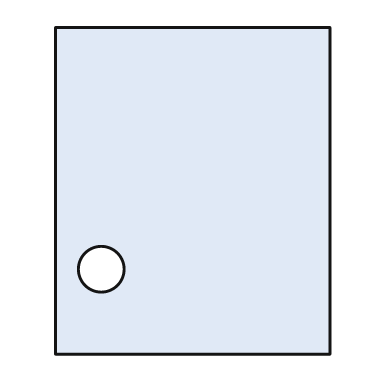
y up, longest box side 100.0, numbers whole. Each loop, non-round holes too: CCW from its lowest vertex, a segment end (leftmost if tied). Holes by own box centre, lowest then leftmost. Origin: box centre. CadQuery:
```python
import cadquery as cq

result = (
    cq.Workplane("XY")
    .moveTo(-42.0, -50.0)
    .lineTo(42.0, -50.0)
    .lineTo(42.0, 50.0)
    .lineTo(-42.0, 50.0)
    .close()
    .moveTo(-28.0, -24.0)
    .circle(7.0)
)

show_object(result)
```